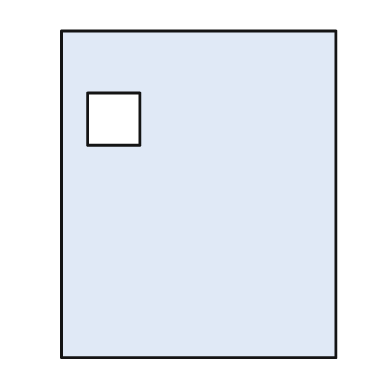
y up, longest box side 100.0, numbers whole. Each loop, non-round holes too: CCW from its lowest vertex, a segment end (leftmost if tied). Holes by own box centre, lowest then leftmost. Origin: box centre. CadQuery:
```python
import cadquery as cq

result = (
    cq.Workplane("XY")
    .moveTo(-42.0, -50.0)
    .lineTo(42.0, -50.0)
    .lineTo(42.0, 50.0)
    .lineTo(-42.0, 50.0)
    .close()
    .moveTo(-34.0, 15.0)
    .lineTo(-18.0, 15.0)
    .lineTo(-18.0, 31.0)
    .lineTo(-34.0, 31.0)
    .close()
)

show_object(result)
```